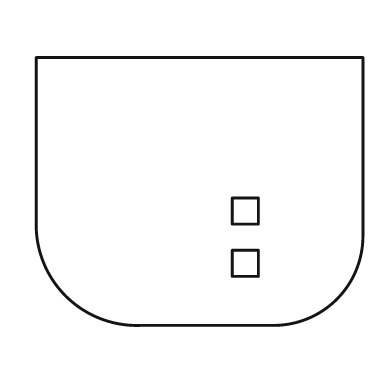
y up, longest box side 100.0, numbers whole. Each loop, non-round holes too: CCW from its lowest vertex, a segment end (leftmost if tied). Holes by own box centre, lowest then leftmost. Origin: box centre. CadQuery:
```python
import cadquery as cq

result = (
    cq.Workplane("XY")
    .moveTo(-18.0, -41.0)
    .lineTo(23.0, -41.0)
    .threePointArc((42.0, -33.0), (50.0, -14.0))
    .lineTo(50.0, 41.0)
    .lineTo(-50.0, 41.0)
    .lineTo(-50.0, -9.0)
    .threePointArc((-41.0, -32.0), (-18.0, -41.0))
    .close()
    .moveTo(10.0, -26.0)
    .lineTo(18.0, -26.0)
    .lineTo(18.0, -18.0)
    .lineTo(10.0, -18.0)
    .close()
    .moveTo(10.0, -10.0)
    .lineTo(18.0, -10.0)
    .lineTo(18.0, -2.0)
    .lineTo(10.0, -2.0)
    .close()
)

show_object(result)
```